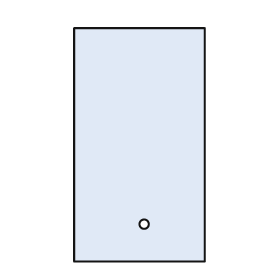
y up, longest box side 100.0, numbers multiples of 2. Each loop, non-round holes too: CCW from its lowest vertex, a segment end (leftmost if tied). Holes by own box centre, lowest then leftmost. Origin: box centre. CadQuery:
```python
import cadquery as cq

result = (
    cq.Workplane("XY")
    .moveTo(-28.0, -50.0)
    .lineTo(28.0, -50.0)
    .lineTo(28.0, 50.0)
    .lineTo(-28.0, 50.0)
    .close()
    .moveTo(2.0, -34.0)
    .circle(2.0)
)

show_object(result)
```